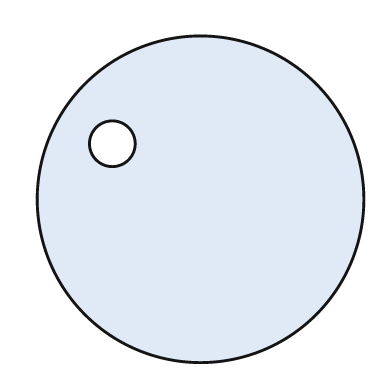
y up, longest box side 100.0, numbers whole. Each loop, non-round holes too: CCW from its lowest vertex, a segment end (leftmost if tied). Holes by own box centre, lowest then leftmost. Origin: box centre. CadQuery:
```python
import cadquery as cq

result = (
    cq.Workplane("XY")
    .moveTo(0.0, 0.0)
    .circle(50.0)
    .moveTo(-27.0, 17.0)
    .circle(7.0)
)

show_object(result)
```